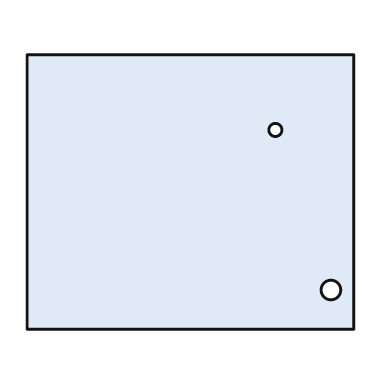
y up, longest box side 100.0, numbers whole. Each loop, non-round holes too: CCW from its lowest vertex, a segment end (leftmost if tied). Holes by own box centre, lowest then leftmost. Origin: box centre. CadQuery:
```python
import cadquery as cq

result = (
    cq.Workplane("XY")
    .moveTo(-50.0, -42.0)
    .lineTo(50.0, -42.0)
    .lineTo(50.0, 42.0)
    .lineTo(-50.0, 42.0)
    .close()
    .moveTo(43.0, -30.0)
    .circle(3.0)
    .moveTo(26.0, 19.0)
    .circle(2.0)
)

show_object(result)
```